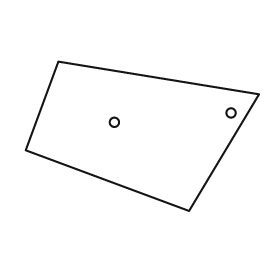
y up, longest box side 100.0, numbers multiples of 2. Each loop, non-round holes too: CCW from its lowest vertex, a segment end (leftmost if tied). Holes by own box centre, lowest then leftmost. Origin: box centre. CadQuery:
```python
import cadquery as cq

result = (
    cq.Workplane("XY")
    .moveTo(20.0, -32.0)
    .lineTo(50.0, 18.0)
    .lineTo(-36.0, 32.0)
    .lineTo(-50.0, -6.0)
    .close()
    .moveTo(-12.0, 6.0)
    .circle(2.0)
    .moveTo(38.0, 10.0)
    .circle(2.0)
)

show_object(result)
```